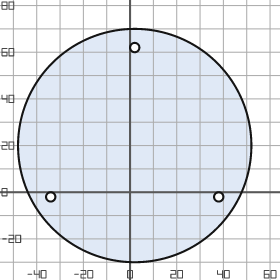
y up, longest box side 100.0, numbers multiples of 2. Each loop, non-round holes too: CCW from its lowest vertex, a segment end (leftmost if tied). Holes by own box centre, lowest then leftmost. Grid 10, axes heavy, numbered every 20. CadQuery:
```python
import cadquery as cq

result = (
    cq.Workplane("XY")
    .moveTo(2.0, 20.0)
    .circle(50.0)
    .moveTo(-34.0, -2.0)
    .circle(2.0)
    .moveTo(38.0, -2.0)
    .circle(2.0)
    .moveTo(2.0, 62.0)
    .circle(2.0)
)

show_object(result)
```